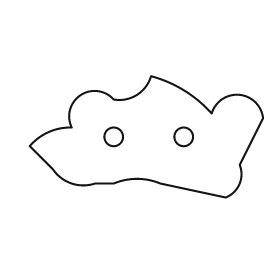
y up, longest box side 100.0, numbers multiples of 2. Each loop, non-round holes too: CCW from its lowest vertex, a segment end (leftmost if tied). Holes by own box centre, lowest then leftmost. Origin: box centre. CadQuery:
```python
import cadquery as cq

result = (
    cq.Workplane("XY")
    .moveTo(34.0, -26.0)
    .threePointArc((40.0, -20.0), (40.0, -12.0))
    .lineTo(50.0, 8.0)
    .threePointArc((40.0, 18.0), (28.0, 10.0))
    .threePointArc((16.0, 20.0), (2.0, 26.0))
    .threePointArc((-4.0, 18.0), (-14.0, 16.0))
    .threePointArc((-28.0, 18.0), (-32.0, 4.0))
    .threePointArc((-42.0, 2.0), (-50.0, -4.0))
    .lineTo(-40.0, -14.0)
    .threePointArc((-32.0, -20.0), (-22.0, -20.0))
    .lineTo(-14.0, -20.0)
    .threePointArc((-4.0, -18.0), (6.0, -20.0))
    .close()
    .moveTo(-14.0, 0.0)
    .circle(4.0)
    .moveTo(16.0, 0.0)
    .circle(4.0)
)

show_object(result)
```